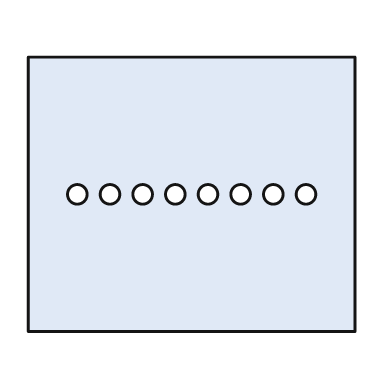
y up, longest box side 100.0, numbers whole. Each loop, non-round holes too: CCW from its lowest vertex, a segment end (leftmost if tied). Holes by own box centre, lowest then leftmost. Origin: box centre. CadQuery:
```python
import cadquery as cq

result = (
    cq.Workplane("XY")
    .moveTo(-50.0, -42.0)
    .lineTo(50.0, -42.0)
    .lineTo(50.0, 42.0)
    .lineTo(-50.0, 42.0)
    .close()
    .moveTo(-35.0, 0.0)
    .circle(3.0)
    .moveTo(-25.0, 0.0)
    .circle(3.0)
    .moveTo(-15.0, 0.0)
    .circle(3.0)
    .moveTo(-5.0, 0.0)
    .circle(3.0)
    .moveTo(5.0, 0.0)
    .circle(3.0)
    .moveTo(15.0, 0.0)
    .circle(3.0)
    .moveTo(25.0, 0.0)
    .circle(3.0)
    .moveTo(35.0, 0.0)
    .circle(3.0)
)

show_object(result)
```